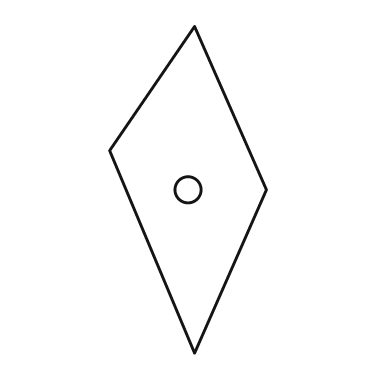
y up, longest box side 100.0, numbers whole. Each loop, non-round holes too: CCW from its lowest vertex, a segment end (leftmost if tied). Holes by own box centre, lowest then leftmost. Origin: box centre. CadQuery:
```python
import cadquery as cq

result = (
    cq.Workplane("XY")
    .moveTo(2.0, -50.0)
    .lineTo(24.0, 0.0)
    .lineTo(2.0, 50.0)
    .lineTo(-24.0, 12.0)
    .close()
    .moveTo(0.0, 0.0)
    .circle(4.0)
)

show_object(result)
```